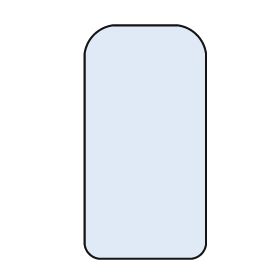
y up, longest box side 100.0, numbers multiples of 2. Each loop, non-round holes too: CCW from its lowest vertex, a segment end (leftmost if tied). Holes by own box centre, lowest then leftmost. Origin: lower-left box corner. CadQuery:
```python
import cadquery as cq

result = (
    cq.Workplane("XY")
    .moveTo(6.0, 0.0)
    .lineTo(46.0, 0.0)
    .threePointArc((50.0, 2.0), (52.0, 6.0))
    .lineTo(52.0, 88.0)
    .threePointArc((48.0, 96.0), (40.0, 100.0))
    .lineTo(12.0, 100.0)
    .threePointArc((4.0, 96.0), (0.0, 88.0))
    .lineTo(0.0, 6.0)
    .threePointArc((2.0, 2.0), (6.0, 0.0))
    .close()
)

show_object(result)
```